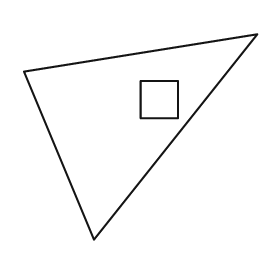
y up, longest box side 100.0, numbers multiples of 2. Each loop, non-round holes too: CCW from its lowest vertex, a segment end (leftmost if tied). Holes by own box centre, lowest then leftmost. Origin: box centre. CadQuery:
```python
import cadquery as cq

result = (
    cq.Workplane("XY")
    .moveTo(-20.0, -44.0)
    .lineTo(50.0, 44.0)
    .lineTo(-50.0, 28.0)
    .close()
    .moveTo(0.0, 8.0)
    .lineTo(16.0, 8.0)
    .lineTo(16.0, 24.0)
    .lineTo(0.0, 24.0)
    .close()
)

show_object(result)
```